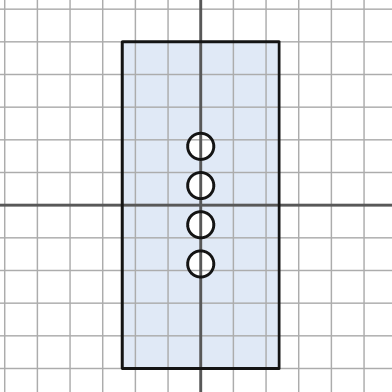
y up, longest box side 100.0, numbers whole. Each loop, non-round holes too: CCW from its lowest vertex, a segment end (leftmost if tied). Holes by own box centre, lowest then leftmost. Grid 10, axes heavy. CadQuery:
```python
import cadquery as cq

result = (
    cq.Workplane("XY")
    .moveTo(-24.0, -50.0)
    .lineTo(24.0, -50.0)
    .lineTo(24.0, 50.0)
    .lineTo(-24.0, 50.0)
    .close()
    .moveTo(0.0, -18.0)
    .circle(4.0)
    .moveTo(0.0, -6.0)
    .circle(4.0)
    .moveTo(0.0, 6.0)
    .circle(4.0)
    .moveTo(0.0, 18.0)
    .circle(4.0)
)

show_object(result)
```